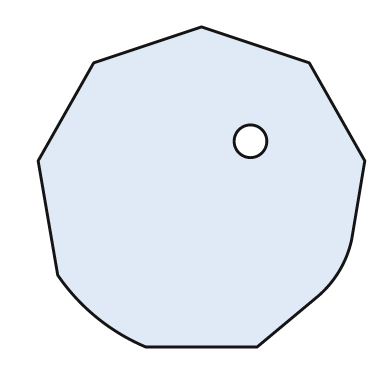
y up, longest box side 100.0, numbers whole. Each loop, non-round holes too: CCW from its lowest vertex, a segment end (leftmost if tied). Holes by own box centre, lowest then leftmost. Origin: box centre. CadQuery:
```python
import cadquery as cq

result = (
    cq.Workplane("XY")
    .moveTo(-17.0, -49.0)
    .lineTo(17.0, -49.0)
    .lineTo(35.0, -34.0)
    .threePointArc((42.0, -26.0), (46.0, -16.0))
    .lineTo(50.0, 8.0)
    .lineTo(33.0, 38.0)
    .lineTo(0.0, 49.0)
    .lineTo(-33.0, 38.0)
    .lineTo(-50.0, 8.0)
    .lineTo(-44.0, -27.0)
    .threePointArc((-32.0, -40.0), (-17.0, -49.0))
    .close()
    .moveTo(15.0, 14.0)
    .circle(5.0)
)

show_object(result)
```